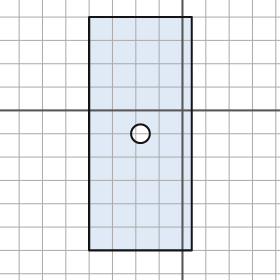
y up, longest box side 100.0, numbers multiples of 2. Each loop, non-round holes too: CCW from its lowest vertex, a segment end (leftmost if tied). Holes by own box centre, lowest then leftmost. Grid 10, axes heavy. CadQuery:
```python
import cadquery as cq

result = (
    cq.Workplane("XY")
    .moveTo(-40.0, -60.0)
    .lineTo(4.0, -60.0)
    .lineTo(4.0, 40.0)
    .lineTo(-40.0, 40.0)
    .close()
    .moveTo(-18.0, -10.0)
    .circle(4.0)
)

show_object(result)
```